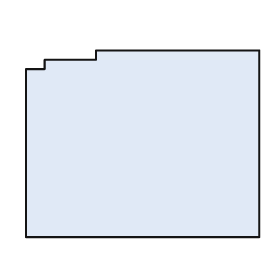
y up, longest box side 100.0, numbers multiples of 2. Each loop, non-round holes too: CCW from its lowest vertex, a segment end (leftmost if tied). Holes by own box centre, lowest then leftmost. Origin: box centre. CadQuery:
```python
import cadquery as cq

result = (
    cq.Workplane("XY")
    .moveTo(-50.0, -40.0)
    .lineTo(50.0, -40.0)
    .lineTo(50.0, 40.0)
    .lineTo(-20.0, 40.0)
    .lineTo(-20.0, 36.0)
    .lineTo(-42.0, 36.0)
    .lineTo(-42.0, 32.0)
    .lineTo(-50.0, 32.0)
    .close()
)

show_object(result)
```